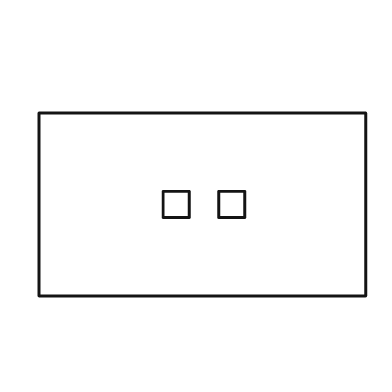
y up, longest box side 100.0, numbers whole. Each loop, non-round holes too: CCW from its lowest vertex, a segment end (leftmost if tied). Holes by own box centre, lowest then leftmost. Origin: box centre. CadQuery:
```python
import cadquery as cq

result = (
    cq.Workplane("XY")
    .moveTo(-50.0, -28.0)
    .lineTo(50.0, -28.0)
    .lineTo(50.0, 28.0)
    .lineTo(-50.0, 28.0)
    .close()
    .moveTo(-12.0, -4.0)
    .lineTo(-4.0, -4.0)
    .lineTo(-4.0, 4.0)
    .lineTo(-12.0, 4.0)
    .close()
    .moveTo(5.0, -4.0)
    .lineTo(13.0, -4.0)
    .lineTo(13.0, 4.0)
    .lineTo(5.0, 4.0)
    .close()
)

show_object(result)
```